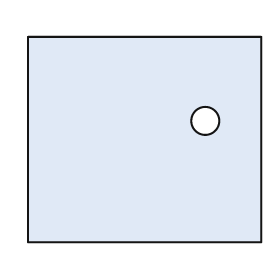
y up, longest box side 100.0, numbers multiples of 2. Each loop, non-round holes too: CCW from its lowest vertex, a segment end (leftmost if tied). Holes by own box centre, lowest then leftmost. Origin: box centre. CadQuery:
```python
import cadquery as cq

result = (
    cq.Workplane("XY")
    .moveTo(-50.0, -44.0)
    .lineTo(50.0, -44.0)
    .lineTo(50.0, 44.0)
    .lineTo(-50.0, 44.0)
    .close()
    .moveTo(26.0, 8.0)
    .circle(6.0)
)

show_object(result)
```